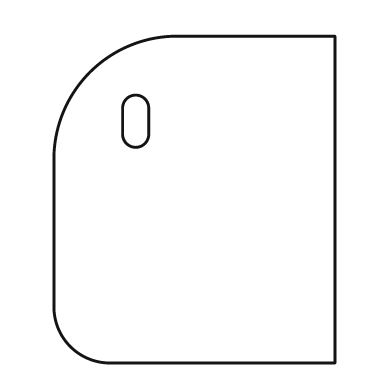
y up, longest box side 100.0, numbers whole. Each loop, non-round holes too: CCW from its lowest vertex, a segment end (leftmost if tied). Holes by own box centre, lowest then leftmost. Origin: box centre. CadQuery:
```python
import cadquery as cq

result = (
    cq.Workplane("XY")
    .moveTo(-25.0, -50.0)
    .lineTo(43.0, -50.0)
    .lineTo(43.0, 50.0)
    .lineTo(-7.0, 50.0)
    .threePointArc((-32.0, 39.0), (-43.0, 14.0))
    .lineTo(-43.0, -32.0)
    .threePointArc((-38.0, -45.0), (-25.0, -50.0))
    .close()
    .moveTo(-22.0, 20.0)
    .threePointArc((-18.0, 16.0), (-14.0, 20.0))
    .lineTo(-14.0, 28.0)
    .threePointArc((-18.0, 32.0), (-22.0, 28.0))
    .close()
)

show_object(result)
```